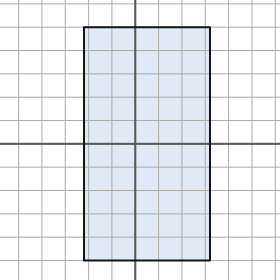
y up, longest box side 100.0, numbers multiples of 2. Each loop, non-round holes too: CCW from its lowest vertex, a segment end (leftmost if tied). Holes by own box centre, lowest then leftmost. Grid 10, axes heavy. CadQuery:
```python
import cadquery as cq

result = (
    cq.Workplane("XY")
    .moveTo(-22.0, -50.0)
    .lineTo(32.0, -50.0)
    .lineTo(32.0, 50.0)
    .lineTo(-22.0, 50.0)
    .close()
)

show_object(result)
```